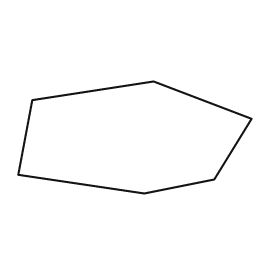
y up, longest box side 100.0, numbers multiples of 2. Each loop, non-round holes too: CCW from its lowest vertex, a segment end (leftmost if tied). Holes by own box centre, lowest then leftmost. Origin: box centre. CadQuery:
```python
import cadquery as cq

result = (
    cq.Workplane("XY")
    .moveTo(4.0, -24.0)
    .lineTo(34.0, -18.0)
    .lineTo(50.0, 8.0)
    .lineTo(8.0, 24.0)
    .lineTo(-44.0, 16.0)
    .lineTo(-50.0, -16.0)
    .close()
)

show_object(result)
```